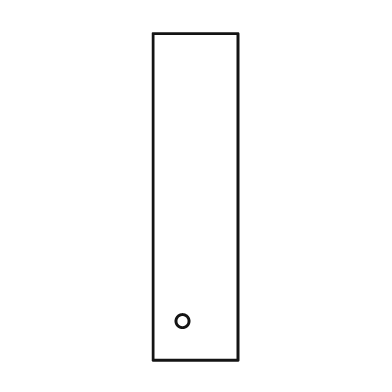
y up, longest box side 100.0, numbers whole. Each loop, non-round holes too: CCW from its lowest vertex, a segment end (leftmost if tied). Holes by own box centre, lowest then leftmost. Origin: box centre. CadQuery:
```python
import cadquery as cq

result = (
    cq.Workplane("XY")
    .moveTo(-13.0, -50.0)
    .lineTo(13.0, -50.0)
    .lineTo(13.0, 50.0)
    .lineTo(-13.0, 50.0)
    .close()
    .moveTo(-4.0, -38.0)
    .circle(2.0)
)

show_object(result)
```